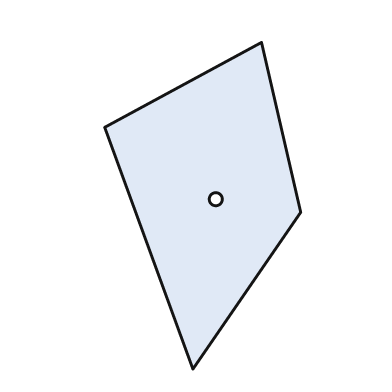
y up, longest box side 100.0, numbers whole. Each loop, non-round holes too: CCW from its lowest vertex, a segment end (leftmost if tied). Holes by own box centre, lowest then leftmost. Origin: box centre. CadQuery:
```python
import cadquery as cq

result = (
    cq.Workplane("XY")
    .moveTo(-3.0, -50.0)
    .lineTo(30.0, -2.0)
    .lineTo(18.0, 50.0)
    .lineTo(-30.0, 24.0)
    .close()
    .moveTo(4.0, 2.0)
    .circle(2.0)
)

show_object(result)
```